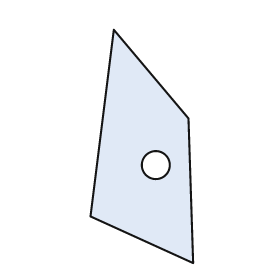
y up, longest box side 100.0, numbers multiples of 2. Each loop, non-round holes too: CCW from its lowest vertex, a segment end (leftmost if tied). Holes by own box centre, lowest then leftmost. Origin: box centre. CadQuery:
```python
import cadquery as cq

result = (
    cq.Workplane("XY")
    .moveTo(22.0, -50.0)
    .lineTo(20.0, 12.0)
    .lineTo(-12.0, 50.0)
    .lineTo(-22.0, -30.0)
    .close()
    .moveTo(6.0, -8.0)
    .circle(6.0)
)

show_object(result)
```